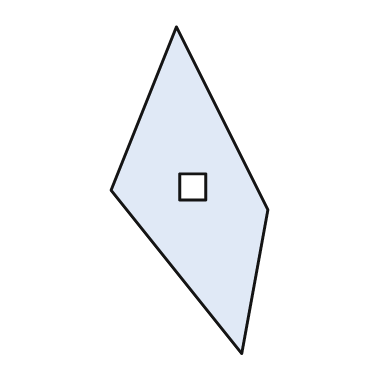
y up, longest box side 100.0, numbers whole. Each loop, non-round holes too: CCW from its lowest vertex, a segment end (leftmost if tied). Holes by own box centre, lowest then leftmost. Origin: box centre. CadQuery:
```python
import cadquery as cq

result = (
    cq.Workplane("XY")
    .moveTo(16.0, -50.0)
    .lineTo(24.0, -6.0)
    .lineTo(-4.0, 50.0)
    .lineTo(-24.0, 0.0)
    .close()
    .moveTo(-3.0, -3.0)
    .lineTo(5.0, -3.0)
    .lineTo(5.0, 5.0)
    .lineTo(-3.0, 5.0)
    .close()
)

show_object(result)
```